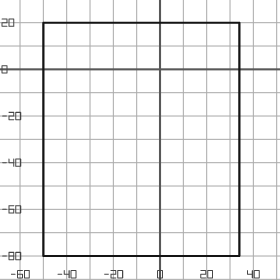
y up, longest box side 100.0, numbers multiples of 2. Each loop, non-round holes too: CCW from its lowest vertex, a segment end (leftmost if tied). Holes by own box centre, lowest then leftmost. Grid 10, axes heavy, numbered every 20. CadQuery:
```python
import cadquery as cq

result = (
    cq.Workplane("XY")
    .moveTo(-50.0, -80.0)
    .lineTo(34.0, -80.0)
    .lineTo(34.0, 20.0)
    .lineTo(-50.0, 20.0)
    .close()
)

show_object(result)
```